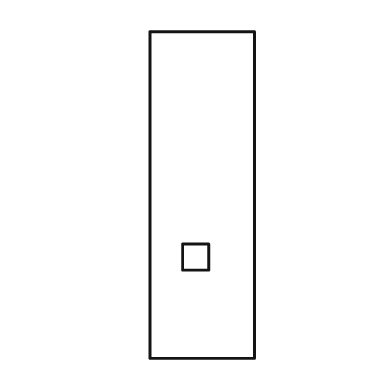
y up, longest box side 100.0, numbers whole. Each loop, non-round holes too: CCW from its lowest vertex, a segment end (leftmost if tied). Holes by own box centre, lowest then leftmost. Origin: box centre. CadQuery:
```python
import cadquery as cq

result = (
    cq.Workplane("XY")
    .moveTo(-16.0, -50.0)
    .lineTo(16.0, -50.0)
    .lineTo(16.0, 50.0)
    .lineTo(-16.0, 50.0)
    .close()
    .moveTo(-6.0, -23.0)
    .lineTo(2.0, -23.0)
    .lineTo(2.0, -15.0)
    .lineTo(-6.0, -15.0)
    .close()
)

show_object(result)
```